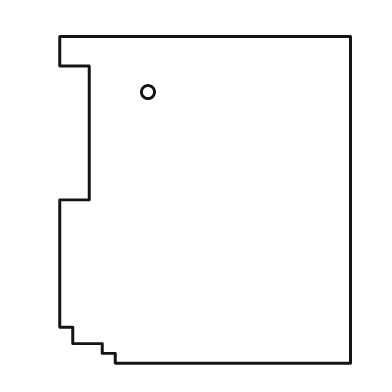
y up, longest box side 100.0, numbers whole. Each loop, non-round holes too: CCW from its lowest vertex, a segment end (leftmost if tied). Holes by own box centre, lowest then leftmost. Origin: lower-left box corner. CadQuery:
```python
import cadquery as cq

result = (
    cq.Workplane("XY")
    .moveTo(17.0, 0.0)
    .lineTo(89.0, 0.0)
    .lineTo(89.0, 100.0)
    .lineTo(0.0, 100.0)
    .lineTo(0.0, 91.0)
    .lineTo(9.0, 91.0)
    .lineTo(9.0, 50.0)
    .lineTo(0.0, 50.0)
    .lineTo(0.0, 11.0)
    .lineTo(4.0, 11.0)
    .lineTo(4.0, 6.0)
    .lineTo(13.0, 6.0)
    .lineTo(13.0, 3.0)
    .lineTo(17.0, 3.0)
    .close()
    .moveTo(27.0, 83.0)
    .circle(2.0)
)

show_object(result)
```